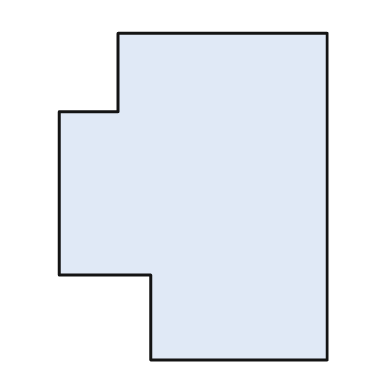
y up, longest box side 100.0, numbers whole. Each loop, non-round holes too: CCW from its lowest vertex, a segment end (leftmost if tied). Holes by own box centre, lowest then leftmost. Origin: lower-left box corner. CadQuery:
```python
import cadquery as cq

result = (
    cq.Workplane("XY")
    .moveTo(28.0, 0.0)
    .lineTo(82.0, 0.0)
    .lineTo(82.0, 100.0)
    .lineTo(18.0, 100.0)
    .lineTo(18.0, 76.0)
    .lineTo(0.0, 76.0)
    .lineTo(0.0, 26.0)
    .lineTo(28.0, 26.0)
    .close()
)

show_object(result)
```